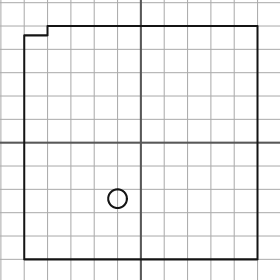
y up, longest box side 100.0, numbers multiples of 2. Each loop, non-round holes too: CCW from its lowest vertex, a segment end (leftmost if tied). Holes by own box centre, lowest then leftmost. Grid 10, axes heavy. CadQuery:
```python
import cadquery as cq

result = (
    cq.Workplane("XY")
    .moveTo(-50.0, -50.0)
    .lineTo(50.0, -50.0)
    .lineTo(50.0, 50.0)
    .lineTo(-40.0, 50.0)
    .lineTo(-40.0, 46.0)
    .lineTo(-50.0, 46.0)
    .close()
    .moveTo(-10.0, -24.0)
    .circle(4.0)
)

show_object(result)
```